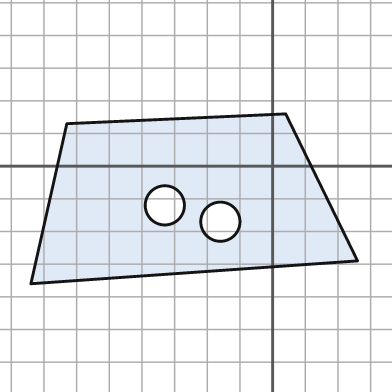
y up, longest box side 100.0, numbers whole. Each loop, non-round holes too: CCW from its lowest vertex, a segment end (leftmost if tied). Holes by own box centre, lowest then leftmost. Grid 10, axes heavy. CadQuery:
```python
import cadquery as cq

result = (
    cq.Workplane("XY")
    .moveTo(-74.0, -36.0)
    .lineTo(26.0, -29.0)
    .lineTo(4.0, 16.0)
    .lineTo(-63.0, 13.0)
    .close()
    .moveTo(-16.0, -17.0)
    .circle(6.0)
    .moveTo(-33.0, -12.0)
    .circle(6.0)
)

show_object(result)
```